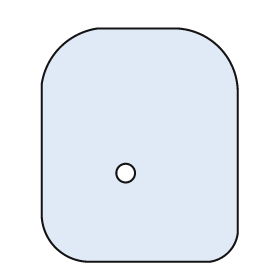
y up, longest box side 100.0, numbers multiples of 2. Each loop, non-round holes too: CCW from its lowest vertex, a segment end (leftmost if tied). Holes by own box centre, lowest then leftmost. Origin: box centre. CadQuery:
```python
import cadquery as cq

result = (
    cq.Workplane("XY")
    .moveTo(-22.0, -50.0)
    .lineTo(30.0, -50.0)
    .threePointArc((38.0, -46.0), (42.0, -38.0))
    .lineTo(42.0, 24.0)
    .threePointArc((34.0, 42.0), (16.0, 50.0))
    .lineTo(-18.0, 50.0)
    .threePointArc((-34.0, 42.0), (-42.0, 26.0))
    .lineTo(-42.0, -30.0)
    .threePointArc((-36.0, -44.0), (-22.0, -50.0))
    .close()
    .moveTo(-6.0, -12.0)
    .circle(4.0)
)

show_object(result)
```